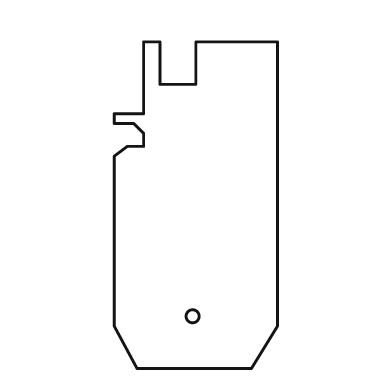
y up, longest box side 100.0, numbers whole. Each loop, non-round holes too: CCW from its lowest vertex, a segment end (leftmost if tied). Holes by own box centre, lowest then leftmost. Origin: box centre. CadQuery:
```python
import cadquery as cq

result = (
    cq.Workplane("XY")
    .moveTo(-18.0, -50.0)
    .lineTo(17.0, -50.0)
    .lineTo(25.0, -37.0)
    .lineTo(25.0, 50.0)
    .lineTo(0.0, 50.0)
    .lineTo(0.0, 37.0)
    .lineTo(-11.0, 37.0)
    .lineTo(-11.0, 50.0)
    .lineTo(-16.0, 50.0)
    .lineTo(-16.0, 28.0)
    .lineTo(-25.0, 28.0)
    .lineTo(-25.0, 25.0)
    .lineTo(-19.0, 25.0)
    .lineTo(-16.0, 22.0)
    .lineTo(-16.0, 18.0)
    .lineTo(-21.0, 18.0)
    .lineTo(-25.0, 15.0)
    .lineTo(-25.0, -37.0)
    .close()
    .moveTo(-1.0, -34.0)
    .circle(2.0)
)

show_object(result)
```